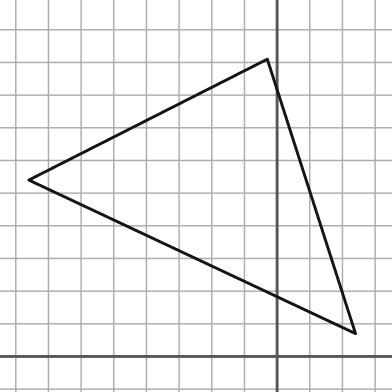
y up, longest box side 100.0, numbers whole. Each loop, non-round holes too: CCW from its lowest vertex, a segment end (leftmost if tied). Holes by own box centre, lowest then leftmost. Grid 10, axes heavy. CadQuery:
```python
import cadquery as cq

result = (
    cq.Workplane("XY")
    .moveTo(24.0, 7.0)
    .lineTo(-3.0, 91.0)
    .lineTo(-76.0, 54.0)
    .close()
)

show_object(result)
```